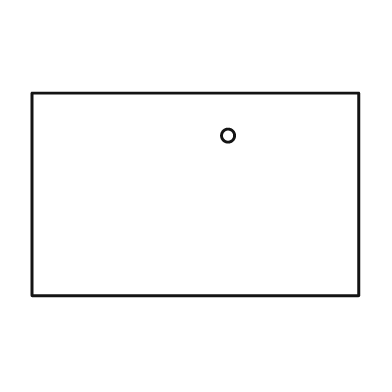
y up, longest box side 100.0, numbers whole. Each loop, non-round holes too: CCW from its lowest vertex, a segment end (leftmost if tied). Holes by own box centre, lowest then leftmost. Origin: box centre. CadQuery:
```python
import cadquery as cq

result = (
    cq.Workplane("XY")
    .moveTo(-50.0, -31.0)
    .lineTo(50.0, -31.0)
    .lineTo(50.0, 31.0)
    .lineTo(-50.0, 31.0)
    .close()
    .moveTo(10.0, 18.0)
    .circle(2.0)
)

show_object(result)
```